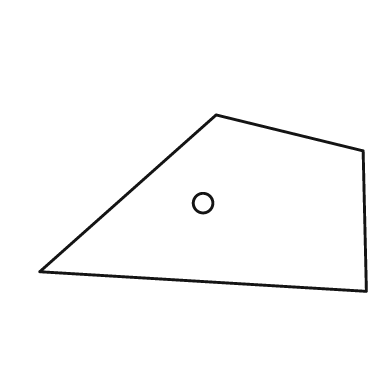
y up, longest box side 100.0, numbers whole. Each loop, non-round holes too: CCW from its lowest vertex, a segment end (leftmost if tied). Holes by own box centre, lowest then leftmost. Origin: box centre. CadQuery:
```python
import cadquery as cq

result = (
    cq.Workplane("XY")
    .moveTo(50.0, -27.0)
    .lineTo(49.0, 16.0)
    .lineTo(4.0, 27.0)
    .lineTo(-50.0, -21.0)
    .close()
    .moveTo(0.0, 0.0)
    .circle(3.0)
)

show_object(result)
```